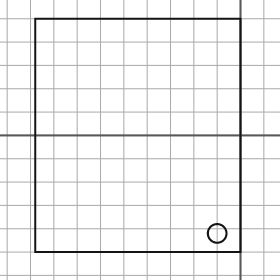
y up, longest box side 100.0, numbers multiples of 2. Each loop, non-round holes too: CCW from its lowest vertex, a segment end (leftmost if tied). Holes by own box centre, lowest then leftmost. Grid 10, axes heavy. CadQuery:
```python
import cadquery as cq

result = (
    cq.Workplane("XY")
    .moveTo(-88.0, -50.0)
    .lineTo(0.0, -50.0)
    .lineTo(0.0, 50.0)
    .lineTo(-88.0, 50.0)
    .close()
    .moveTo(-10.0, -42.0)
    .circle(4.0)
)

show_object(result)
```